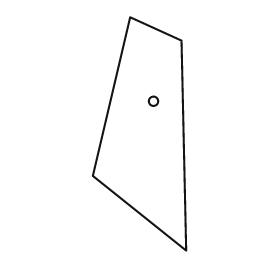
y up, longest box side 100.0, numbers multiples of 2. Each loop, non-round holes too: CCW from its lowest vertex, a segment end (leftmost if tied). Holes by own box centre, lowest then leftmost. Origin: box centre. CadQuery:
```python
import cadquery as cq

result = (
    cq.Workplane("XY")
    .moveTo(20.0, -50.0)
    .lineTo(18.0, 40.0)
    .lineTo(-4.0, 50.0)
    .lineTo(-20.0, -18.0)
    .close()
    .moveTo(6.0, 14.0)
    .circle(2.0)
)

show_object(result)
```